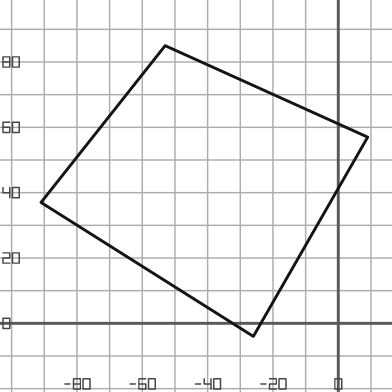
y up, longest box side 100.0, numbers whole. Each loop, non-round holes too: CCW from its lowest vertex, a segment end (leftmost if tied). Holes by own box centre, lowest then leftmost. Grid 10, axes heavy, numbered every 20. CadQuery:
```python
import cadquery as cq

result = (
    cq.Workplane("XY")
    .moveTo(-26.0, -4.0)
    .lineTo(9.0, 57.0)
    .lineTo(-53.0, 85.0)
    .lineTo(-91.0, 37.0)
    .close()
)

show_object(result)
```